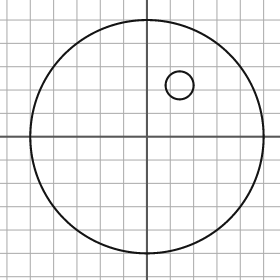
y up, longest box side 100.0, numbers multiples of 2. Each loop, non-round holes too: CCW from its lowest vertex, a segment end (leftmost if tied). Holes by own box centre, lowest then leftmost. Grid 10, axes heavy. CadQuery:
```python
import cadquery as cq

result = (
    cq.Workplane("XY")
    .moveTo(0.0, 0.0)
    .circle(50.0)
    .moveTo(14.0, 22.0)
    .circle(6.0)
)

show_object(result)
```